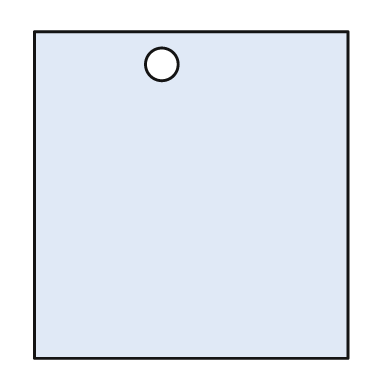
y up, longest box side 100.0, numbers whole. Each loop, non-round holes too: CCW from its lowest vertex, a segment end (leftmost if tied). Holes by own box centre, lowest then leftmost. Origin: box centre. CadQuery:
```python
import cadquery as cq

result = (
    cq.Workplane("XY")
    .moveTo(-48.0, -50.0)
    .lineTo(48.0, -50.0)
    .lineTo(48.0, 50.0)
    .lineTo(-48.0, 50.0)
    .close()
    .moveTo(-9.0, 40.0)
    .circle(5.0)
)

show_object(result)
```